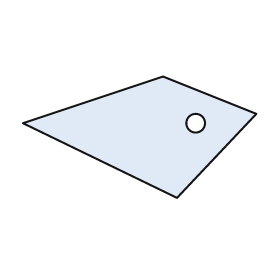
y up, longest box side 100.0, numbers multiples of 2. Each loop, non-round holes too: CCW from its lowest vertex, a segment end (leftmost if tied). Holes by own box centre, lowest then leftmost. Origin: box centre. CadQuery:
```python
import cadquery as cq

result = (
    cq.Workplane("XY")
    .moveTo(16.0, -26.0)
    .lineTo(50.0, 10.0)
    .lineTo(10.0, 26.0)
    .lineTo(-50.0, 6.0)
    .close()
    .moveTo(24.0, 6.0)
    .circle(4.0)
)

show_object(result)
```